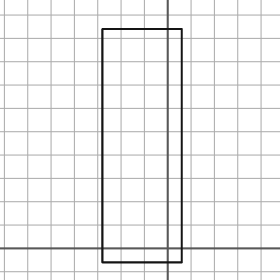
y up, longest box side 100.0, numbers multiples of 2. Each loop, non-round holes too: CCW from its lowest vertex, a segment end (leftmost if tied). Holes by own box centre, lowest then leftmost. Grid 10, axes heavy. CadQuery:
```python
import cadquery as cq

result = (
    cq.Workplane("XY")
    .moveTo(-28.0, -6.0)
    .lineTo(6.0, -6.0)
    .lineTo(6.0, 94.0)
    .lineTo(-28.0, 94.0)
    .close()
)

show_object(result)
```